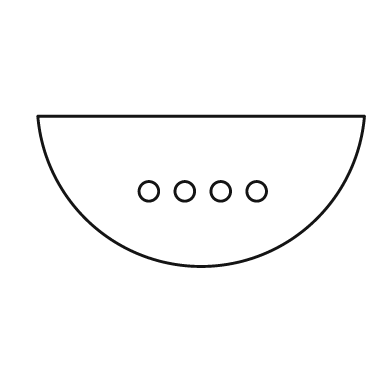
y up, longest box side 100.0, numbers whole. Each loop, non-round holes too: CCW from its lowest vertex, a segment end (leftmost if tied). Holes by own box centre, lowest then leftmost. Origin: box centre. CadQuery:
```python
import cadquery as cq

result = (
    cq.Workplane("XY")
    .moveTo(-50.0, 23.0)
    .threePointArc((0.0, -23.0), (50.0, 23.0))
    .close()
    .moveTo(-16.0, 0.0)
    .circle(3.0)
    .moveTo(-5.0, 0.0)
    .circle(3.0)
    .moveTo(6.0, 0.0)
    .circle(3.0)
    .moveTo(17.0, 0.0)
    .circle(3.0)
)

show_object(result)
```